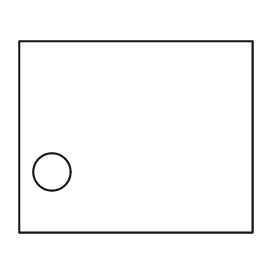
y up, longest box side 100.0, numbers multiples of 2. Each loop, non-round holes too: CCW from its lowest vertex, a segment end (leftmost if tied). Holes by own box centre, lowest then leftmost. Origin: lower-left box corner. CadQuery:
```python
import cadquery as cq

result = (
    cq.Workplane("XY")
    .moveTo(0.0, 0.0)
    .lineTo(100.0, 0.0)
    .lineTo(100.0, 82.0)
    .lineTo(0.0, 82.0)
    .close()
    .moveTo(14.0, 26.0)
    .circle(8.0)
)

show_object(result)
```